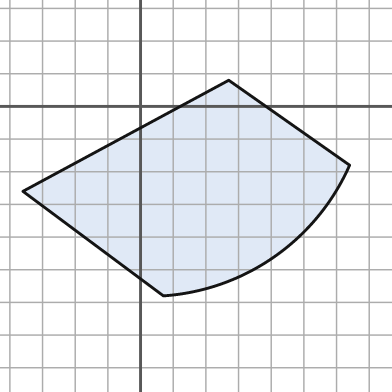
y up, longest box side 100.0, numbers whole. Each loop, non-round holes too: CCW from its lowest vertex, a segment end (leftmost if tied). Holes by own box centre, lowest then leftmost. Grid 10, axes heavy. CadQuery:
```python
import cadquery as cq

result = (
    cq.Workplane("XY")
    .moveTo(7.0, -58.0)
    .threePointArc((41.0, -46.0), (64.0, -18.0))
    .lineTo(27.0, 8.0)
    .lineTo(-36.0, -26.0)
    .close()
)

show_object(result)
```